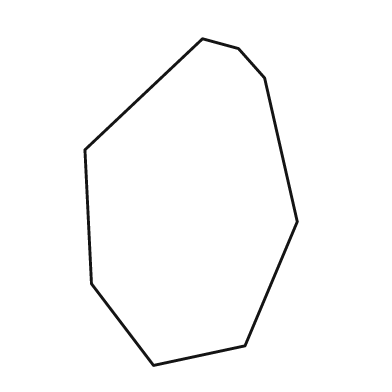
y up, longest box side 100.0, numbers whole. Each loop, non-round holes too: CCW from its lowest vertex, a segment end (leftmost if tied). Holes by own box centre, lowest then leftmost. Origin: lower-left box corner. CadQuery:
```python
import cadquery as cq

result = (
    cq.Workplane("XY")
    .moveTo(21.0, 0.0)
    .lineTo(49.0, 6.0)
    .lineTo(65.0, 44.0)
    .lineTo(55.0, 88.0)
    .lineTo(47.0, 97.0)
    .lineTo(36.0, 100.0)
    .lineTo(0.0, 66.0)
    .lineTo(2.0, 25.0)
    .close()
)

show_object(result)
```